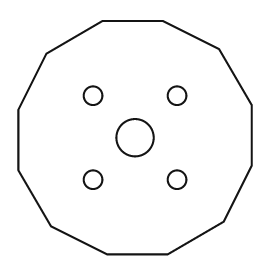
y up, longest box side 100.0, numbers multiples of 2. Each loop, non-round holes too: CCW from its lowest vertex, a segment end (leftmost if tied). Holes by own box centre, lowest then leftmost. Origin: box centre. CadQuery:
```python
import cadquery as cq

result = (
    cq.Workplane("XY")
    .moveTo(-12.0, -50.0)
    .lineTo(14.0, -50.0)
    .lineTo(38.0, -36.0)
    .lineTo(50.0, -12.0)
    .lineTo(50.0, 14.0)
    .lineTo(36.0, 38.0)
    .lineTo(12.0, 50.0)
    .lineTo(-14.0, 50.0)
    .lineTo(-38.0, 36.0)
    .lineTo(-50.0, 12.0)
    .lineTo(-50.0, -14.0)
    .lineTo(-36.0, -38.0)
    .close()
    .moveTo(-18.0, -18.0)
    .circle(4.0)
    .moveTo(18.0, -18.0)
    .circle(4.0)
    .moveTo(0.0, 0.0)
    .circle(8.0)
    .moveTo(-18.0, 18.0)
    .circle(4.0)
    .moveTo(18.0, 18.0)
    .circle(4.0)
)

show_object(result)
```